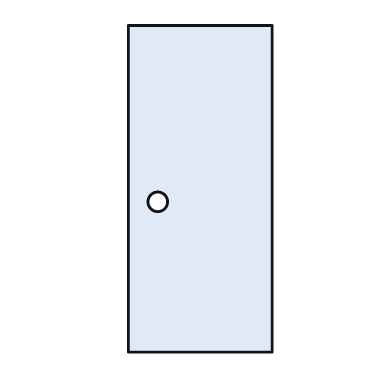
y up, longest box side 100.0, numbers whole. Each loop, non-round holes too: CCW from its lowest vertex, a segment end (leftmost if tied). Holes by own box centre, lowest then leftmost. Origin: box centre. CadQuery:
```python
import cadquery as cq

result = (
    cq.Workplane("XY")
    .moveTo(-22.0, -50.0)
    .lineTo(22.0, -50.0)
    .lineTo(22.0, 50.0)
    .lineTo(-22.0, 50.0)
    .close()
    .moveTo(-13.0, -4.0)
    .circle(3.0)
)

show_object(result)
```